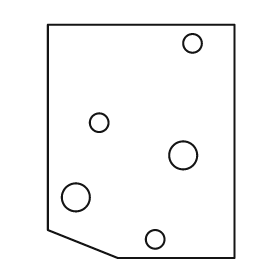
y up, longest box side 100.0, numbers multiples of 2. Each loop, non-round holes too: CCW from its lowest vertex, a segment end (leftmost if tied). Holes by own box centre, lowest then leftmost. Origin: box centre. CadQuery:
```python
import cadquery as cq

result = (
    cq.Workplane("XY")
    .moveTo(-10.0, -50.0)
    .lineTo(40.0, -50.0)
    .lineTo(40.0, 50.0)
    .lineTo(-40.0, 50.0)
    .lineTo(-40.0, -38.0)
    .close()
    .moveTo(6.0, -42.0)
    .circle(4.0)
    .moveTo(-28.0, -24.0)
    .circle(6.0)
    .moveTo(18.0, -6.0)
    .circle(6.0)
    .moveTo(-18.0, 8.0)
    .circle(4.0)
    .moveTo(22.0, 42.0)
    .circle(4.0)
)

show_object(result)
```